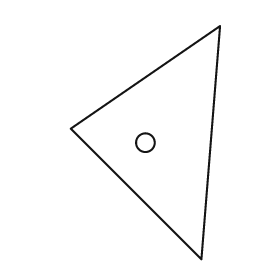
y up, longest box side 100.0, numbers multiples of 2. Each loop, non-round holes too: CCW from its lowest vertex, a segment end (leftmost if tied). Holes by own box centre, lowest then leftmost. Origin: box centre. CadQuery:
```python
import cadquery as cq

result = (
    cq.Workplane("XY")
    .moveTo(24.0, -50.0)
    .lineTo(32.0, 50.0)
    .lineTo(-32.0, 6.0)
    .close()
    .moveTo(0.0, 0.0)
    .circle(4.0)
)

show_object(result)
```